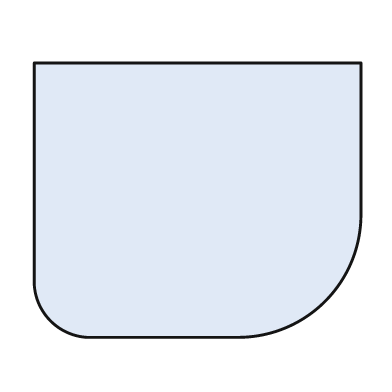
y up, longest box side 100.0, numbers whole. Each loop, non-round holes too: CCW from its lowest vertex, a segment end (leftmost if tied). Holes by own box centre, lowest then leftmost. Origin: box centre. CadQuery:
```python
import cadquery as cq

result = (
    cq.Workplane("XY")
    .moveTo(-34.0, -42.0)
    .lineTo(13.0, -42.0)
    .threePointArc((39.0, -31.0), (50.0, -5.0))
    .lineTo(50.0, 42.0)
    .lineTo(-50.0, 42.0)
    .lineTo(-50.0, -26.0)
    .threePointArc((-45.0, -37.0), (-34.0, -42.0))
    .close()
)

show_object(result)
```